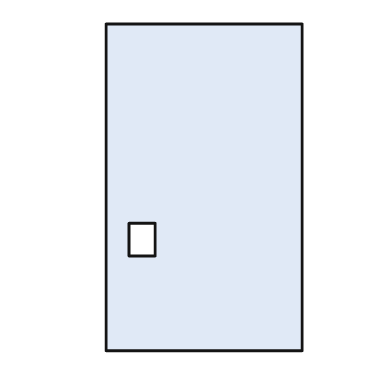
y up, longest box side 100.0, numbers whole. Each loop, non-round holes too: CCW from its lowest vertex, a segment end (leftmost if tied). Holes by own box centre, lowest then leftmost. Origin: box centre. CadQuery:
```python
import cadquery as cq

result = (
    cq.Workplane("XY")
    .moveTo(-30.0, -50.0)
    .lineTo(30.0, -50.0)
    .lineTo(30.0, 50.0)
    .lineTo(-30.0, 50.0)
    .close()
    .moveTo(-23.0, -21.0)
    .lineTo(-15.0, -21.0)
    .lineTo(-15.0, -11.0)
    .lineTo(-23.0, -11.0)
    .close()
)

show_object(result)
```